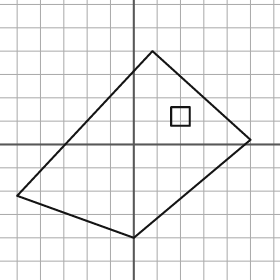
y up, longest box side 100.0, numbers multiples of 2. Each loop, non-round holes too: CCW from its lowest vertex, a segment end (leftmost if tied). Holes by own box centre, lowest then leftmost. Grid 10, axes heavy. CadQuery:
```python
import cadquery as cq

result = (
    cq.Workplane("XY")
    .moveTo(0.0, -40.0)
    .lineTo(50.0, 2.0)
    .lineTo(8.0, 40.0)
    .lineTo(-50.0, -22.0)
    .close()
    .moveTo(16.0, 8.0)
    .lineTo(24.0, 8.0)
    .lineTo(24.0, 16.0)
    .lineTo(16.0, 16.0)
    .close()
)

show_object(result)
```